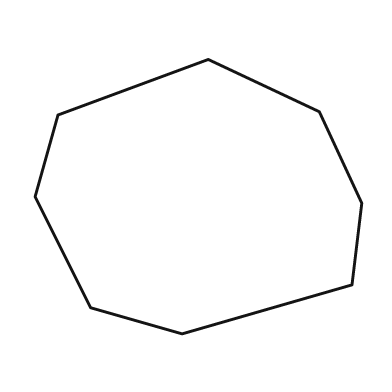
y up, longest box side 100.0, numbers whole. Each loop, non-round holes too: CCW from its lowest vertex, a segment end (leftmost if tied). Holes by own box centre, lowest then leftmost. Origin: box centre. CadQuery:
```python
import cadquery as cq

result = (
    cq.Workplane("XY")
    .moveTo(-5.0, -42.0)
    .lineTo(47.0, -27.0)
    .lineTo(50.0, -2.0)
    .lineTo(37.0, 26.0)
    .lineTo(3.0, 42.0)
    .lineTo(-43.0, 25.0)
    .lineTo(-50.0, 0.0)
    .lineTo(-33.0, -34.0)
    .close()
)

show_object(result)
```